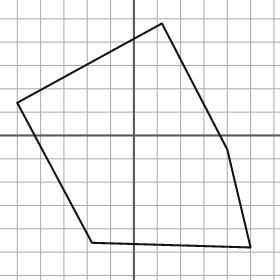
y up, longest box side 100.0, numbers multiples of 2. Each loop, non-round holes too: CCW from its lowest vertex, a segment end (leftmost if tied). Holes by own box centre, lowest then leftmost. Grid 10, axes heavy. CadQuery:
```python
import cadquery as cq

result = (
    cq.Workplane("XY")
    .moveTo(50.0, -48.0)
    .lineTo(40.0, -6.0)
    .lineTo(12.0, 48.0)
    .lineTo(-50.0, 14.0)
    .lineTo(-18.0, -46.0)
    .close()
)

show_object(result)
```